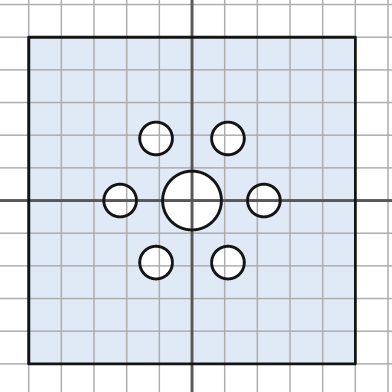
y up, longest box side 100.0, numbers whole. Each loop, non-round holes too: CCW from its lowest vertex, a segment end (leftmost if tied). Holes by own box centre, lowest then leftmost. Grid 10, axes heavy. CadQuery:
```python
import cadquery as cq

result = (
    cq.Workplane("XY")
    .moveTo(-50.0, -50.0)
    .lineTo(50.0, -50.0)
    .lineTo(50.0, 50.0)
    .lineTo(-50.0, 50.0)
    .close()
    .moveTo(-11.0, -19.0)
    .circle(5.0)
    .moveTo(11.0, -19.0)
    .circle(5.0)
    .moveTo(-22.0, 0.0)
    .circle(5.0)
    .moveTo(0.0, 0.0)
    .circle(9.0)
    .moveTo(22.0, 0.0)
    .circle(5.0)
    .moveTo(-11.0, 19.0)
    .circle(5.0)
    .moveTo(11.0, 19.0)
    .circle(5.0)
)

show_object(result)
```